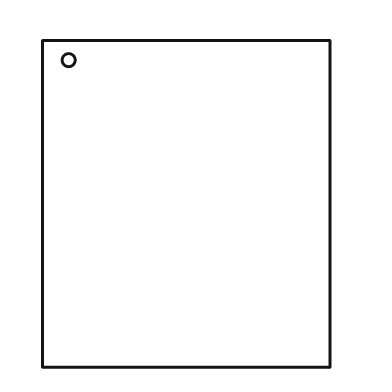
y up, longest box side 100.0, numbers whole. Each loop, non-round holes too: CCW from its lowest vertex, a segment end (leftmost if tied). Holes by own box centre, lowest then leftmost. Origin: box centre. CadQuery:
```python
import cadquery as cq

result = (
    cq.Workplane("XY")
    .moveTo(-44.0, -50.0)
    .lineTo(44.0, -50.0)
    .lineTo(44.0, 50.0)
    .lineTo(-44.0, 50.0)
    .close()
    .moveTo(-36.0, 44.0)
    .circle(2.0)
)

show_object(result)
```